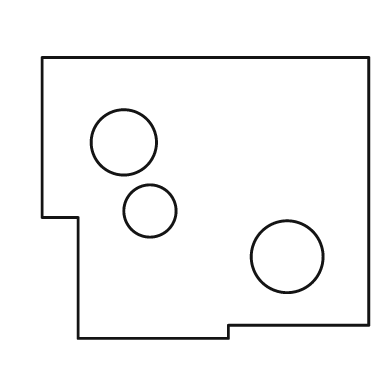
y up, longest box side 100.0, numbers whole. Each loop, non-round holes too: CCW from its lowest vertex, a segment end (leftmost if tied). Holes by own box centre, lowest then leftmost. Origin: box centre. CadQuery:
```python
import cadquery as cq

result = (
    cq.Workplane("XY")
    .moveTo(-39.0, -43.0)
    .lineTo(7.0, -43.0)
    .lineTo(7.0, -39.0)
    .lineTo(50.0, -39.0)
    .lineTo(50.0, 43.0)
    .lineTo(-50.0, 43.0)
    .lineTo(-50.0, -6.0)
    .lineTo(-39.0, -6.0)
    .close()
    .moveTo(25.0, -18.0)
    .circle(11.0)
    .moveTo(-17.0, -4.0)
    .circle(8.0)
    .moveTo(-25.0, 17.0)
    .circle(10.0)
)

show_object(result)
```